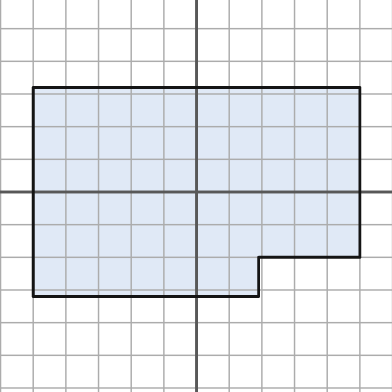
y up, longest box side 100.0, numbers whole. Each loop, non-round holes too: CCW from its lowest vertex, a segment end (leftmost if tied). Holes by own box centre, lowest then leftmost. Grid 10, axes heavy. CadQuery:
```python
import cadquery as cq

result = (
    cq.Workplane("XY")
    .moveTo(-50.0, -32.0)
    .lineTo(19.0, -32.0)
    .lineTo(19.0, -20.0)
    .lineTo(50.0, -20.0)
    .lineTo(50.0, 32.0)
    .lineTo(-50.0, 32.0)
    .close()
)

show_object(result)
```